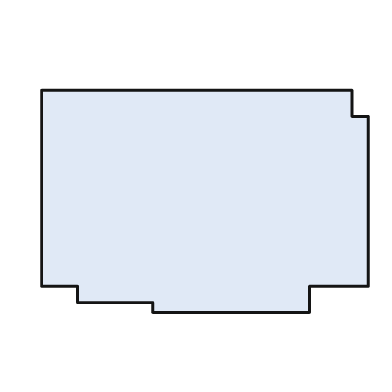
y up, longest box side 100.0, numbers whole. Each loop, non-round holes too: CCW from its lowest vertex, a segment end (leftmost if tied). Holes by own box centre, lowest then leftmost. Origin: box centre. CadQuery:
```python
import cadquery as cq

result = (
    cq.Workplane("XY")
    .moveTo(-16.0, -34.0)
    .lineTo(32.0, -34.0)
    .lineTo(32.0, -26.0)
    .lineTo(50.0, -26.0)
    .lineTo(50.0, 26.0)
    .lineTo(45.0, 26.0)
    .lineTo(45.0, 34.0)
    .lineTo(-50.0, 34.0)
    .lineTo(-50.0, -26.0)
    .lineTo(-39.0, -26.0)
    .lineTo(-39.0, -31.0)
    .lineTo(-16.0, -31.0)
    .close()
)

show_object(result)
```